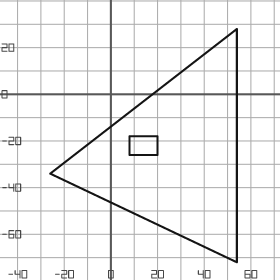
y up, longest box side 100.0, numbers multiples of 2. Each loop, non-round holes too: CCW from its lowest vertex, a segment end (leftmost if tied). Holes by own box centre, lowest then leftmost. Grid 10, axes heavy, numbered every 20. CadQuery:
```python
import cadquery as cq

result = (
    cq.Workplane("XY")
    .moveTo(54.0, -72.0)
    .lineTo(54.0, 28.0)
    .lineTo(-26.0, -34.0)
    .close()
    .moveTo(8.0, -26.0)
    .lineTo(20.0, -26.0)
    .lineTo(20.0, -18.0)
    .lineTo(8.0, -18.0)
    .close()
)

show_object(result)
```